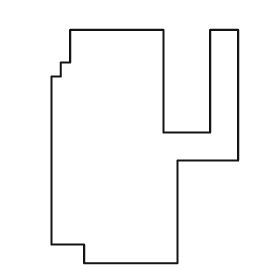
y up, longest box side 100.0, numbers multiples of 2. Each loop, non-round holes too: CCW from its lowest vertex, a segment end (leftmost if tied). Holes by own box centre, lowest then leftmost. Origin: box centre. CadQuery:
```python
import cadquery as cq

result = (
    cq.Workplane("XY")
    .moveTo(-26.0, -50.0)
    .lineTo(14.0, -50.0)
    .lineTo(14.0, -6.0)
    .lineTo(40.0, -6.0)
    .lineTo(40.0, 50.0)
    .lineTo(28.0, 50.0)
    .lineTo(28.0, 6.0)
    .lineTo(8.0, 6.0)
    .lineTo(8.0, 50.0)
    .lineTo(-32.0, 50.0)
    .lineTo(-32.0, 36.0)
    .lineTo(-36.0, 36.0)
    .lineTo(-36.0, 30.0)
    .lineTo(-40.0, 30.0)
    .lineTo(-40.0, -42.0)
    .lineTo(-26.0, -42.0)
    .close()
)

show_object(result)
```